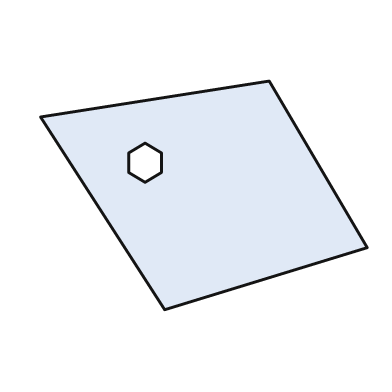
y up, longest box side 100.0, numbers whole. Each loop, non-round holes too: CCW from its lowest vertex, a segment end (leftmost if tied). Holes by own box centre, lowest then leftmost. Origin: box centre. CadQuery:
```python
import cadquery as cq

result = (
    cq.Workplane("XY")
    .moveTo(-12.0, -35.0)
    .lineTo(50.0, -16.0)
    .lineTo(20.0, 35.0)
    .lineTo(-50.0, 24.0)
    .close()
    .moveTo(-18.0, 4.0)
    .lineTo(-13.0, 7.0)
    .lineTo(-13.0, 13.0)
    .lineTo(-18.0, 16.0)
    .lineTo(-23.0, 13.0)
    .lineTo(-23.0, 7.0)
    .close()
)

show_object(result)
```